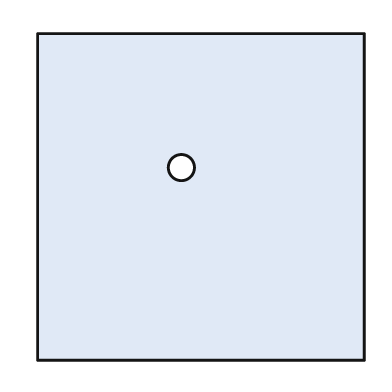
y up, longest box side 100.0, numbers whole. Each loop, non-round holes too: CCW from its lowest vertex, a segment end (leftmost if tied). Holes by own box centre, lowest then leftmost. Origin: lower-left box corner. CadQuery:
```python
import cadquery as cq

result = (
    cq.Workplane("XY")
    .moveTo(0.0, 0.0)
    .lineTo(100.0, 0.0)
    .lineTo(100.0, 100.0)
    .lineTo(0.0, 100.0)
    .close()
    .moveTo(44.0, 59.0)
    .circle(4.0)
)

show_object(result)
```